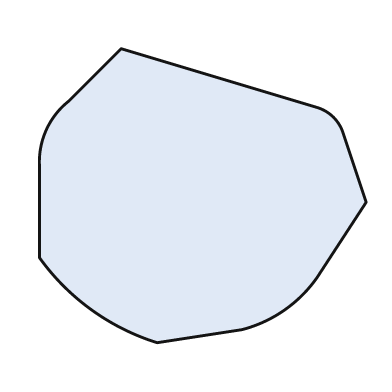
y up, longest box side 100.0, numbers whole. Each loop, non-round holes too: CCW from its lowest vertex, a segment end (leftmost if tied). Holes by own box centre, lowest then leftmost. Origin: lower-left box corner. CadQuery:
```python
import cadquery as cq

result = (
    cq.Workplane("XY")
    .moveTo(36.0, 0.0)
    .lineTo(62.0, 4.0)
    .threePointArc((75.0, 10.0), (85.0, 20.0))
    .lineTo(100.0, 43.0)
    .lineTo(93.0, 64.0)
    .threePointArc((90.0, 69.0), (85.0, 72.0))
    .lineTo(25.0, 90.0)
    .lineTo(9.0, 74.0)
    .threePointArc((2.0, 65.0), (0.0, 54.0))
    .lineTo(0.0, 26.0)
    .threePointArc((16.0, 10.0), (36.0, 0.0))
    .close()
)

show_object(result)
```